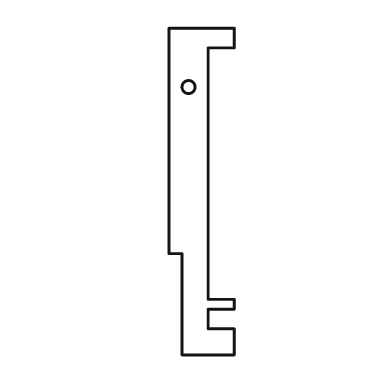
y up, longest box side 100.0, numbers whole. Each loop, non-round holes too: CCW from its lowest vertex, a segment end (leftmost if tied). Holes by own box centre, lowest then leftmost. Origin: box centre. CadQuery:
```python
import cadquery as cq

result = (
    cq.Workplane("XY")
    .moveTo(-6.0, -50.0)
    .lineTo(10.0, -50.0)
    .lineTo(10.0, -42.0)
    .lineTo(2.0, -42.0)
    .lineTo(2.0, -36.0)
    .lineTo(10.0, -36.0)
    .lineTo(10.0, -33.0)
    .lineTo(2.0, -33.0)
    .lineTo(2.0, 44.0)
    .lineTo(10.0, 44.0)
    .lineTo(10.0, 50.0)
    .lineTo(-10.0, 50.0)
    .lineTo(-10.0, -19.0)
    .lineTo(-6.0, -19.0)
    .close()
    .moveTo(-4.0, 32.0)
    .circle(2.0)
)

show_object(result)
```